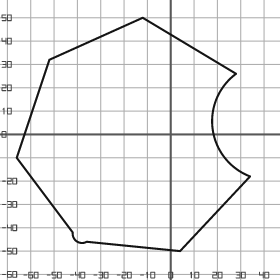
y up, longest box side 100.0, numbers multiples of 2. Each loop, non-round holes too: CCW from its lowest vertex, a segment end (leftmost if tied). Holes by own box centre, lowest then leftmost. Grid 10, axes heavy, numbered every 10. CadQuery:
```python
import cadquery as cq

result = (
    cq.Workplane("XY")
    .moveTo(4.0, -50.0)
    .lineTo(34.0, -18.0)
    .threePointArc((18.0, 2.0), (28.0, 26.0))
    .lineTo(-12.0, 50.0)
    .lineTo(-52.0, 32.0)
    .lineTo(-66.0, -10.0)
    .lineTo(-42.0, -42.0)
    .threePointArc((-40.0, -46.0), (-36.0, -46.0))
    .close()
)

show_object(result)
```